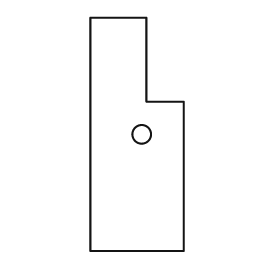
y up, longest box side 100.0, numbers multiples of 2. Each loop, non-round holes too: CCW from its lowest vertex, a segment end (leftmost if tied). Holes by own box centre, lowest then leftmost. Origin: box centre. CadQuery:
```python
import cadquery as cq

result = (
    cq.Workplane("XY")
    .moveTo(-20.0, -50.0)
    .lineTo(20.0, -50.0)
    .lineTo(20.0, 14.0)
    .lineTo(4.0, 14.0)
    .lineTo(4.0, 50.0)
    .lineTo(-20.0, 50.0)
    .close()
    .moveTo(2.0, 0.0)
    .circle(4.0)
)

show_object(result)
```